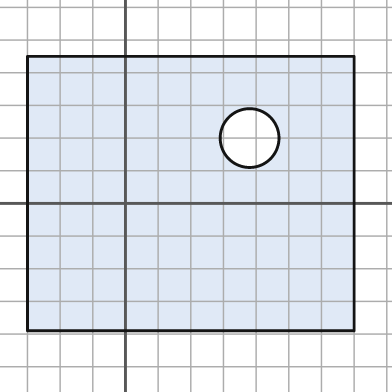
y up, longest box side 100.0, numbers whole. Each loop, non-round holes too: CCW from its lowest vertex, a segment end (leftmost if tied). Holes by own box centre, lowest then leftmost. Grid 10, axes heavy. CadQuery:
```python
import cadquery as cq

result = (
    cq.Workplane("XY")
    .moveTo(-30.0, -39.0)
    .lineTo(70.0, -39.0)
    .lineTo(70.0, 45.0)
    .lineTo(-30.0, 45.0)
    .close()
    .moveTo(38.0, 20.0)
    .circle(9.0)
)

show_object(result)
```